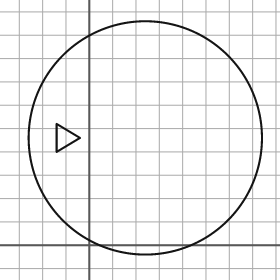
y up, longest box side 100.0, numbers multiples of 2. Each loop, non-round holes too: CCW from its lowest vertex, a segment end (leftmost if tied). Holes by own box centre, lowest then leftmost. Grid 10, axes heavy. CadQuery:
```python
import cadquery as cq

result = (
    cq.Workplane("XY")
    .moveTo(24.0, 46.0)
    .circle(50.0)
    .moveTo(-14.0, 40.0)
    .lineTo(-4.0, 46.0)
    .lineTo(-14.0, 52.0)
    .close()
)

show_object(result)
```